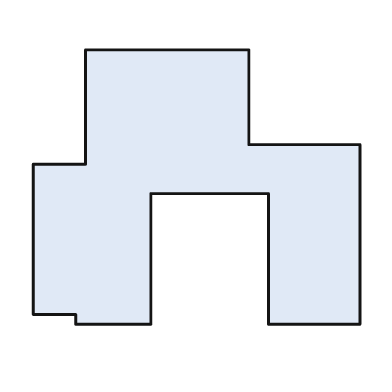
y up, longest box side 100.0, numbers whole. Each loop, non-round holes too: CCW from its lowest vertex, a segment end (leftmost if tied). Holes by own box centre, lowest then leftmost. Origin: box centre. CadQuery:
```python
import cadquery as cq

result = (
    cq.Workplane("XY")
    .moveTo(-37.0, -42.0)
    .lineTo(-14.0, -42.0)
    .lineTo(-14.0, -2.0)
    .lineTo(22.0, -2.0)
    .lineTo(22.0, -42.0)
    .lineTo(50.0, -42.0)
    .lineTo(50.0, 13.0)
    .lineTo(16.0, 13.0)
    .lineTo(16.0, 42.0)
    .lineTo(-34.0, 42.0)
    .lineTo(-34.0, 7.0)
    .lineTo(-50.0, 7.0)
    .lineTo(-50.0, -39.0)
    .lineTo(-37.0, -39.0)
    .close()
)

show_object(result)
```